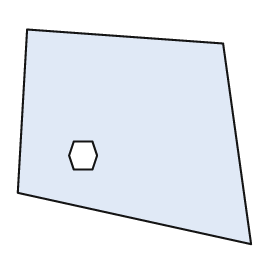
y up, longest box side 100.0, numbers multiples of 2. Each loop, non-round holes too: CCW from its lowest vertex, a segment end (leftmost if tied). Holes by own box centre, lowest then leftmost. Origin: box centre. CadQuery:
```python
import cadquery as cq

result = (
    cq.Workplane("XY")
    .moveTo(50.0, -46.0)
    .lineTo(38.0, 40.0)
    .lineTo(-46.0, 46.0)
    .lineTo(-50.0, -24.0)
    .close()
    .moveTo(-26.0, -14.0)
    .lineTo(-18.0, -14.0)
    .lineTo(-16.0, -8.0)
    .lineTo(-18.0, -2.0)
    .lineTo(-26.0, -2.0)
    .lineTo(-28.0, -8.0)
    .close()
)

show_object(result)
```